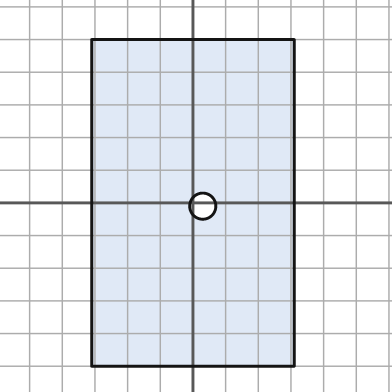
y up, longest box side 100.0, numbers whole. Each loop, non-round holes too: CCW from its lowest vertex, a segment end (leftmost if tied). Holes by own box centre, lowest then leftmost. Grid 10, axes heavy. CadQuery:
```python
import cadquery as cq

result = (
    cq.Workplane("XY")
    .moveTo(-31.0, -50.0)
    .lineTo(31.0, -50.0)
    .lineTo(31.0, 50.0)
    .lineTo(-31.0, 50.0)
    .close()
    .moveTo(3.0, -1.0)
    .circle(4.0)
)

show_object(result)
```